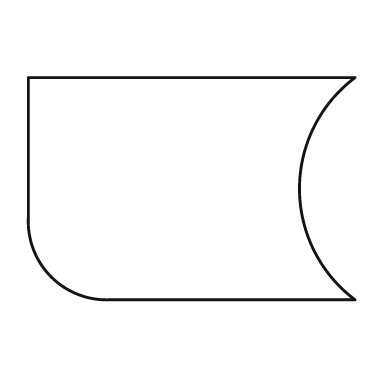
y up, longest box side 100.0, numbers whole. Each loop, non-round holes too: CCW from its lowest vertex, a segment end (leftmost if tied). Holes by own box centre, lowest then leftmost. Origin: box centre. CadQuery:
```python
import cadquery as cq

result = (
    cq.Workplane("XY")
    .moveTo(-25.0, -34.0)
    .lineTo(50.0, -34.0)
    .threePointArc((33.0, 0.0), (50.0, 34.0))
    .lineTo(-50.0, 34.0)
    .lineTo(-50.0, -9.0)
    .threePointArc((-43.0, -27.0), (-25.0, -34.0))
    .close()
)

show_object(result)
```